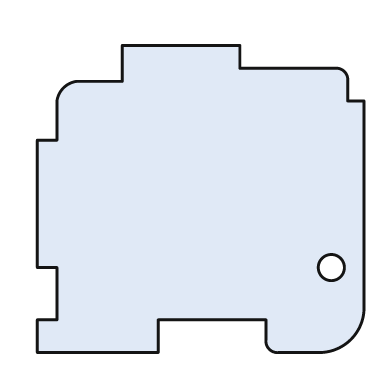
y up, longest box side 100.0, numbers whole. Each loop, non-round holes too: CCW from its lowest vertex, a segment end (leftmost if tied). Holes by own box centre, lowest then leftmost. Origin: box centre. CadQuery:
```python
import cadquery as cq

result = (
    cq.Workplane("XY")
    .moveTo(-50.0, -47.0)
    .lineTo(-13.0, -47.0)
    .lineTo(-13.0, -37.0)
    .lineTo(20.0, -37.0)
    .lineTo(20.0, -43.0)
    .threePointArc((21.0, -46.0), (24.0, -47.0))
    .lineTo(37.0, -47.0)
    .threePointArc((46.0, -43.0), (50.0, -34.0))
    .lineTo(50.0, 30.0)
    .lineTo(45.0, 30.0)
    .lineTo(45.0, 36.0)
    .threePointArc((44.0, 39.0), (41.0, 40.0))
    .lineTo(12.0, 40.0)
    .lineTo(12.0, 47.0)
    .lineTo(-24.0, 47.0)
    .lineTo(-24.0, 36.0)
    .lineTo(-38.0, 36.0)
    .threePointArc((-42.0, 34.0), (-44.0, 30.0))
    .lineTo(-44.0, 18.0)
    .lineTo(-50.0, 18.0)
    .lineTo(-50.0, -21.0)
    .lineTo(-44.0, -21.0)
    .lineTo(-44.0, -37.0)
    .lineTo(-50.0, -37.0)
    .close()
    .moveTo(40.0, -21.0)
    .circle(4.0)
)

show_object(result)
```